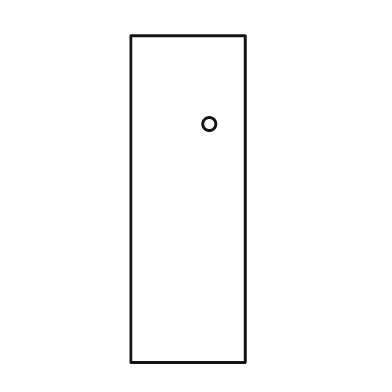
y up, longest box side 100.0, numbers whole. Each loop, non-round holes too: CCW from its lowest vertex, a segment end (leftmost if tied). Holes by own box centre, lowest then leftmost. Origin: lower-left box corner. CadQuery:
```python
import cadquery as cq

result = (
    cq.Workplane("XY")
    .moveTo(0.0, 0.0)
    .lineTo(35.0, 0.0)
    .lineTo(35.0, 100.0)
    .lineTo(0.0, 100.0)
    .close()
    .moveTo(24.0, 73.0)
    .circle(2.0)
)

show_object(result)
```